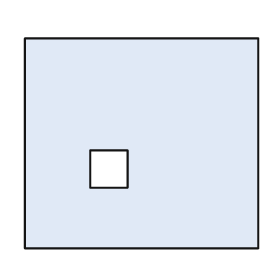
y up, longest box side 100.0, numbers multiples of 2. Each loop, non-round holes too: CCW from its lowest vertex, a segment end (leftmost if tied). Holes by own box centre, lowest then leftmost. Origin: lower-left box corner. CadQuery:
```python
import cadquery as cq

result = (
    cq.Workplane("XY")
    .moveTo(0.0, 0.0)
    .lineTo(100.0, 0.0)
    .lineTo(100.0, 90.0)
    .lineTo(0.0, 90.0)
    .close()
    .moveTo(28.0, 26.0)
    .lineTo(44.0, 26.0)
    .lineTo(44.0, 42.0)
    .lineTo(28.0, 42.0)
    .close()
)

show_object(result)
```